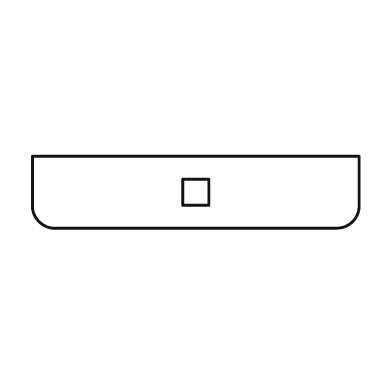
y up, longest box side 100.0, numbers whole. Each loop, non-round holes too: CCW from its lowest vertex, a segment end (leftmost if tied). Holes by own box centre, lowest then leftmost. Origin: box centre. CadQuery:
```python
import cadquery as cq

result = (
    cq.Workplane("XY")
    .moveTo(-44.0, -11.0)
    .lineTo(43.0, -11.0)
    .threePointArc((48.0, -9.0), (50.0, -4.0))
    .lineTo(50.0, 11.0)
    .lineTo(-50.0, 11.0)
    .lineTo(-50.0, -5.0)
    .threePointArc((-48.0, -9.0), (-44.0, -11.0))
    .close()
    .moveTo(-4.0, -4.0)
    .lineTo(4.0, -4.0)
    .lineTo(4.0, 4.0)
    .lineTo(-4.0, 4.0)
    .close()
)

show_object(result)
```